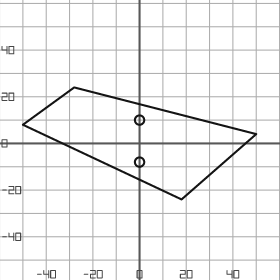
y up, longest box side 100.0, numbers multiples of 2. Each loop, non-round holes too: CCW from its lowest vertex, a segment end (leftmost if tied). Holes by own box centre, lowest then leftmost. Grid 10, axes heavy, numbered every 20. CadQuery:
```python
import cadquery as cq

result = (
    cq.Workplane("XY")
    .moveTo(18.0, -24.0)
    .lineTo(50.0, 4.0)
    .lineTo(-28.0, 24.0)
    .lineTo(-50.0, 8.0)
    .close()
    .moveTo(0.0, -8.0)
    .circle(2.0)
    .moveTo(0.0, 10.0)
    .circle(2.0)
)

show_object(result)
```